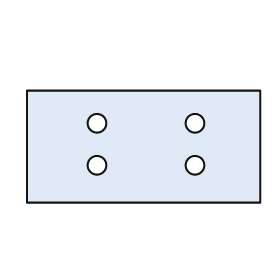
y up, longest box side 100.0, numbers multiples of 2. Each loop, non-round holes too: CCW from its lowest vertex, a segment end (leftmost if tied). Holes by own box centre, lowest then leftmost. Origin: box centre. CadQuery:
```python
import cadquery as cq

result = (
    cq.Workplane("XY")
    .moveTo(-50.0, -24.0)
    .lineTo(50.0, -24.0)
    .lineTo(50.0, 24.0)
    .lineTo(-50.0, 24.0)
    .close()
    .moveTo(-20.0, -8.0)
    .circle(4.0)
    .moveTo(22.0, -8.0)
    .circle(4.0)
    .moveTo(-20.0, 10.0)
    .circle(4.0)
    .moveTo(22.0, 10.0)
    .circle(4.0)
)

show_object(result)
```